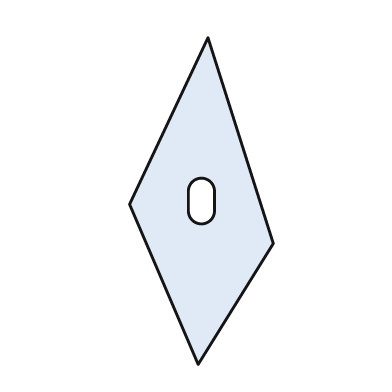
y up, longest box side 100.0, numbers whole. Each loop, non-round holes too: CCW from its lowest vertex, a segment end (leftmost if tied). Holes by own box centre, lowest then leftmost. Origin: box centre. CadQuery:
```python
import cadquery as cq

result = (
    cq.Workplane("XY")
    .moveTo(-1.0, -50.0)
    .lineTo(22.0, -13.0)
    .lineTo(2.0, 50.0)
    .lineTo(-22.0, -1.0)
    .close()
    .moveTo(-4.0, -3.0)
    .threePointArc((0.0, -7.0), (4.0, -3.0))
    .lineTo(4.0, 3.0)
    .threePointArc((0.0, 7.0), (-4.0, 3.0))
    .close()
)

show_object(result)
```